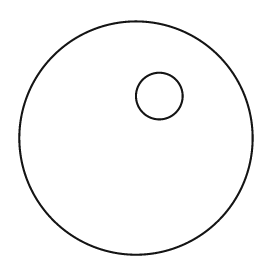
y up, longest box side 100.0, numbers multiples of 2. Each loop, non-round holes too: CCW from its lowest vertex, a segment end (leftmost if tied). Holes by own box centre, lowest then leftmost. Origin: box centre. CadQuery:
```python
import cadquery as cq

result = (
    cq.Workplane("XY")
    .moveTo(0.0, 0.0)
    .circle(50.0)
    .moveTo(10.0, 18.0)
    .circle(10.0)
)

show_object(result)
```